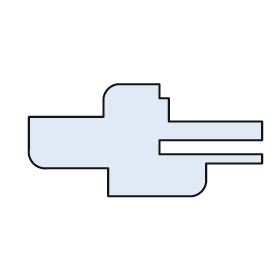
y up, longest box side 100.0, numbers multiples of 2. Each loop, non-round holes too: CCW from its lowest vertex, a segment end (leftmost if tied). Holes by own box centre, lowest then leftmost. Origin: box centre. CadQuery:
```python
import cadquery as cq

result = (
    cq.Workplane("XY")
    .moveTo(-16.0, -24.0)
    .lineTo(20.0, -24.0)
    .threePointArc((24.0, -22.0), (26.0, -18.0))
    .lineTo(26.0, -10.0)
    .lineTo(50.0, -10.0)
    .lineTo(50.0, -6.0)
    .lineTo(6.0, -6.0)
    .lineTo(6.0, 0.0)
    .lineTo(50.0, 0.0)
    .lineTo(50.0, 8.0)
    .lineTo(10.0, 8.0)
    .lineTo(10.0, 18.0)
    .lineTo(6.0, 18.0)
    .lineTo(6.0, 24.0)
    .lineTo(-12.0, 24.0)
    .threePointArc((-16.0, 22.0), (-18.0, 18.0))
    .lineTo(-18.0, 10.0)
    .lineTo(-50.0, 10.0)
    .lineTo(-50.0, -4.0)
    .threePointArc((-48.0, -10.0), (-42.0, -12.0))
    .lineTo(-16.0, -12.0)
    .close()
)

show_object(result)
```